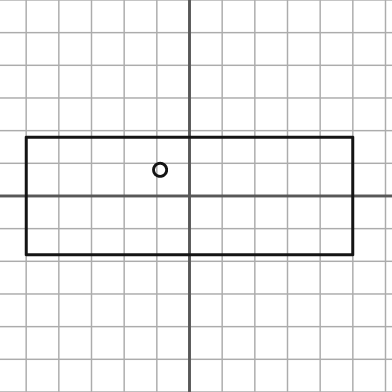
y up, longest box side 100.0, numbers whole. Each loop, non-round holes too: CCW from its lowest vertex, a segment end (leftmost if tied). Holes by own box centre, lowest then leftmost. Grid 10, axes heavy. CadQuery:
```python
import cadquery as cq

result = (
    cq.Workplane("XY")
    .moveTo(-50.0, -18.0)
    .lineTo(50.0, -18.0)
    .lineTo(50.0, 18.0)
    .lineTo(-50.0, 18.0)
    .close()
    .moveTo(-9.0, 8.0)
    .circle(2.0)
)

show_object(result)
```